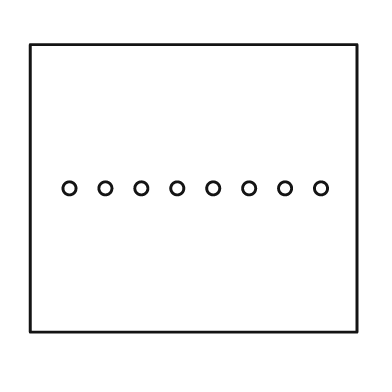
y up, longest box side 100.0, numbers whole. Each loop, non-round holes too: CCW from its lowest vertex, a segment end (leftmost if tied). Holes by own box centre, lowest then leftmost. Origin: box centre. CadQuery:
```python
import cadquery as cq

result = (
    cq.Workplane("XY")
    .moveTo(-50.0, -44.0)
    .lineTo(50.0, -44.0)
    .lineTo(50.0, 44.0)
    .lineTo(-50.0, 44.0)
    .close()
    .moveTo(-38.0, 0.0)
    .circle(2.0)
    .moveTo(-27.0, 0.0)
    .circle(2.0)
    .moveTo(-16.0, 0.0)
    .circle(2.0)
    .moveTo(-5.0, 0.0)
    .circle(2.0)
    .moveTo(6.0, 0.0)
    .circle(2.0)
    .moveTo(17.0, 0.0)
    .circle(2.0)
    .moveTo(28.0, 0.0)
    .circle(2.0)
    .moveTo(39.0, 0.0)
    .circle(2.0)
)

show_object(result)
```